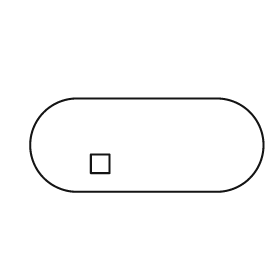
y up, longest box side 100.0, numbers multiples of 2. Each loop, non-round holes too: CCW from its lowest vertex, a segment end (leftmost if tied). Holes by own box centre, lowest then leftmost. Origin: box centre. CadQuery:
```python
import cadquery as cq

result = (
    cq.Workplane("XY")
    .moveTo(-30.0, -20.0)
    .lineTo(30.0, -20.0)
    .threePointArc((50.0, 0.0), (30.0, 20.0))
    .lineTo(-30.0, 20.0)
    .threePointArc((-50.0, 0.0), (-30.0, -20.0))
    .close()
    .moveTo(-24.0, -12.0)
    .lineTo(-16.0, -12.0)
    .lineTo(-16.0, -4.0)
    .lineTo(-24.0, -4.0)
    .close()
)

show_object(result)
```